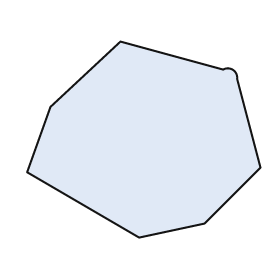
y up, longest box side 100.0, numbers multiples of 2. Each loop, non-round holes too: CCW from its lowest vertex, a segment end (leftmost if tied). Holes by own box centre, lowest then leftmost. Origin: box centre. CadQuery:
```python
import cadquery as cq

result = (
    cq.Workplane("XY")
    .moveTo(-2.0, -42.0)
    .lineTo(26.0, -36.0)
    .lineTo(50.0, -12.0)
    .lineTo(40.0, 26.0)
    .threePointArc((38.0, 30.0), (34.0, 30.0))
    .lineTo(-10.0, 42.0)
    .lineTo(-40.0, 14.0)
    .lineTo(-50.0, -14.0)
    .close()
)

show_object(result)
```